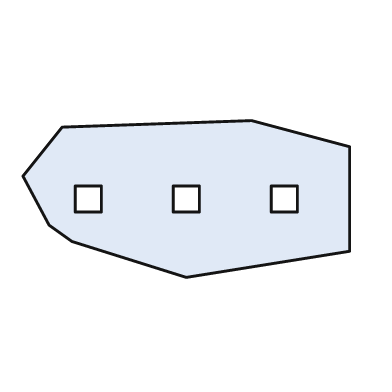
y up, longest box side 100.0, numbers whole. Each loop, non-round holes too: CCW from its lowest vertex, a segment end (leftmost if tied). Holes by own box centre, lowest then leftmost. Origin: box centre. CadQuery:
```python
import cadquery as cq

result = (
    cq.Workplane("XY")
    .moveTo(0.0, -24.0)
    .lineTo(50.0, -16.0)
    .lineTo(50.0, 16.0)
    .lineTo(20.0, 24.0)
    .lineTo(-38.0, 22.0)
    .lineTo(-50.0, 7.0)
    .lineTo(-42.0, -8.0)
    .lineTo(-35.0, -13.0)
    .close()
    .moveTo(-34.0, -4.0)
    .lineTo(-26.0, -4.0)
    .lineTo(-26.0, 4.0)
    .lineTo(-34.0, 4.0)
    .close()
    .moveTo(-4.0, -4.0)
    .lineTo(4.0, -4.0)
    .lineTo(4.0, 4.0)
    .lineTo(-4.0, 4.0)
    .close()
    .moveTo(26.0, -4.0)
    .lineTo(34.0, -4.0)
    .lineTo(34.0, 4.0)
    .lineTo(26.0, 4.0)
    .close()
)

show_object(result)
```